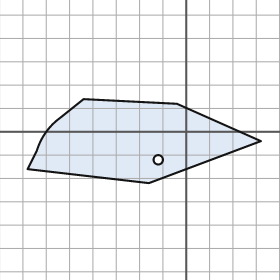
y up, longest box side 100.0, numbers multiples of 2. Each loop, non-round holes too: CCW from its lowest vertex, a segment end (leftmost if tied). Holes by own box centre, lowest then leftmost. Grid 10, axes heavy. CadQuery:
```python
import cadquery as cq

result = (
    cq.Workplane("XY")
    .moveTo(-16.0, -22.0)
    .lineTo(32.0, -4.0)
    .lineTo(-4.0, 12.0)
    .lineTo(-44.0, 14.0)
    .lineTo(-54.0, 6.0)
    .threePointArc((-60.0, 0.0), (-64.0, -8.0))
    .lineTo(-68.0, -16.0)
    .close()
    .moveTo(-12.0, -12.0)
    .circle(2.0)
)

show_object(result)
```